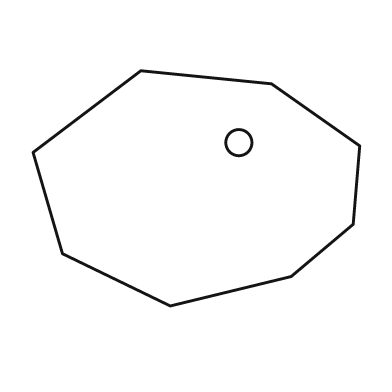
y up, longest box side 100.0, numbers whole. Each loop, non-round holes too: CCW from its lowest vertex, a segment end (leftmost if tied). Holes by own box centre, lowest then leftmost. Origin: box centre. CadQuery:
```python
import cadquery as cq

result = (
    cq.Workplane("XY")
    .moveTo(-8.0, -36.0)
    .lineTo(29.0, -27.0)
    .lineTo(48.0, -11.0)
    .lineTo(50.0, 13.0)
    .lineTo(23.0, 32.0)
    .lineTo(-17.0, 36.0)
    .lineTo(-50.0, 11.0)
    .lineTo(-41.0, -20.0)
    .close()
    .moveTo(13.0, 14.0)
    .circle(4.0)
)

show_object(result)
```